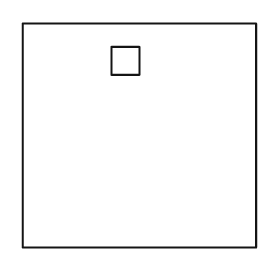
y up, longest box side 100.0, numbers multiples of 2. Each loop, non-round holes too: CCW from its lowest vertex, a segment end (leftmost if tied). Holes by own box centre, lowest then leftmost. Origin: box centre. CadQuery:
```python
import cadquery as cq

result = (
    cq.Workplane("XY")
    .moveTo(-50.0, -48.0)
    .lineTo(50.0, -48.0)
    .lineTo(50.0, 48.0)
    .lineTo(-50.0, 48.0)
    .close()
    .moveTo(-12.0, 26.0)
    .lineTo(0.0, 26.0)
    .lineTo(0.0, 38.0)
    .lineTo(-12.0, 38.0)
    .close()
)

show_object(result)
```